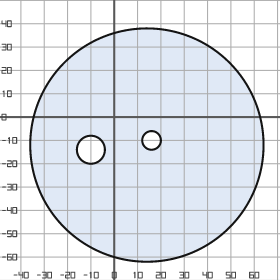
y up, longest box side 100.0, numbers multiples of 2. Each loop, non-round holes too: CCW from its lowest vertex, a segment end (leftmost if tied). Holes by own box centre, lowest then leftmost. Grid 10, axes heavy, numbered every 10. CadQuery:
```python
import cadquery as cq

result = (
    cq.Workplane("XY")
    .moveTo(14.0, -12.0)
    .circle(50.0)
    .moveTo(-10.0, -14.0)
    .circle(6.0)
    .moveTo(16.0, -10.0)
    .circle(4.0)
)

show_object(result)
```